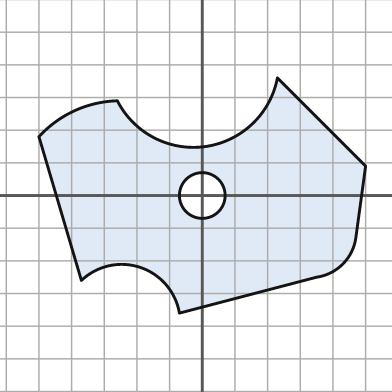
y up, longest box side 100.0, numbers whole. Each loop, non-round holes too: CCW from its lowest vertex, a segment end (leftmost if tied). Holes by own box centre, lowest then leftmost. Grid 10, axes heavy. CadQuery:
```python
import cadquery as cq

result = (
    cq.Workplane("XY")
    .moveTo(-7.0, -36.0)
    .lineTo(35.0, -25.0)
    .threePointArc((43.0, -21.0), (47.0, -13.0))
    .lineTo(50.0, 9.0)
    .lineTo(23.0, 36.0)
    .threePointArc((1.0, 15.0), (-26.0, 29.0))
    .threePointArc((-39.0, 26.0), (-50.0, 18.0))
    .lineTo(-37.0, -26.0)
    .threePointArc((-19.0, -22.0), (-7.0, -36.0))
    .close()
    .moveTo(0.0, 0.0)
    .circle(7.0)
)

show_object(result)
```